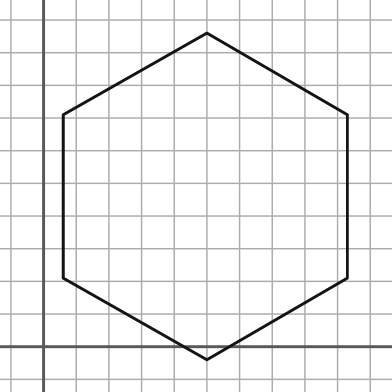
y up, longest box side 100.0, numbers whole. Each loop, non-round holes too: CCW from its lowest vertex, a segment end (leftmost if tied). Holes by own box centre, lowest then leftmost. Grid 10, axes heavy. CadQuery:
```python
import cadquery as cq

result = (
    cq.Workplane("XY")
    .moveTo(50.0, -4.0)
    .lineTo(93.0, 21.0)
    .lineTo(93.0, 71.0)
    .lineTo(50.0, 96.0)
    .lineTo(6.0, 71.0)
    .lineTo(6.0, 21.0)
    .close()
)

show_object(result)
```